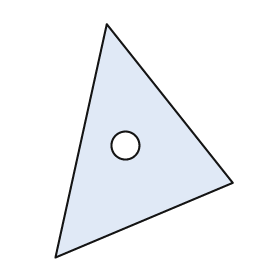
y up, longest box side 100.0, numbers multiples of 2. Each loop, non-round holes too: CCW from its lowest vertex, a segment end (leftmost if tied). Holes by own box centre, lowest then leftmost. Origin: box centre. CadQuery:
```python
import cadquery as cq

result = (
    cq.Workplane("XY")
    .moveTo(-38.0, -50.0)
    .lineTo(38.0, -18.0)
    .lineTo(-16.0, 50.0)
    .close()
    .moveTo(-8.0, -2.0)
    .circle(6.0)
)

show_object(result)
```